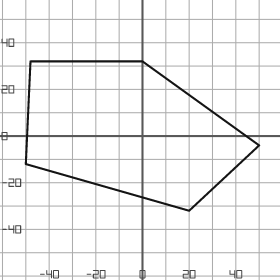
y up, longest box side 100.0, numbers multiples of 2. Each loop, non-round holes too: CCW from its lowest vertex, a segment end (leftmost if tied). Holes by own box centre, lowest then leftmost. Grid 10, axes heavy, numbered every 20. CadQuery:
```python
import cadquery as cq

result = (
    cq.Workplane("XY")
    .moveTo(20.0, -32.0)
    .lineTo(50.0, -4.0)
    .lineTo(0.0, 32.0)
    .lineTo(-48.0, 32.0)
    .lineTo(-50.0, -12.0)
    .close()
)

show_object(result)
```